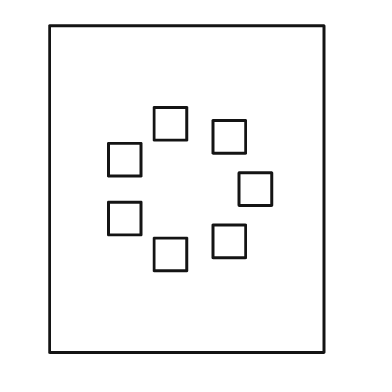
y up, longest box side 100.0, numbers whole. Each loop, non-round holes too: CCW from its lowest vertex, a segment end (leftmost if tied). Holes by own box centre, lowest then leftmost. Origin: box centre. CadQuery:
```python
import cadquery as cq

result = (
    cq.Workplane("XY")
    .moveTo(-42.0, -50.0)
    .lineTo(42.0, -50.0)
    .lineTo(42.0, 50.0)
    .lineTo(-42.0, 50.0)
    .close()
    .moveTo(-10.0, -25.0)
    .lineTo(0.0, -25.0)
    .lineTo(0.0, -15.0)
    .lineTo(-10.0, -15.0)
    .close()
    .moveTo(8.0, -21.0)
    .lineTo(18.0, -21.0)
    .lineTo(18.0, -11.0)
    .lineTo(8.0, -11.0)
    .close()
    .moveTo(-24.0, -14.0)
    .lineTo(-14.0, -14.0)
    .lineTo(-14.0, -4.0)
    .lineTo(-24.0, -4.0)
    .close()
    .moveTo(16.0, -5.0)
    .lineTo(26.0, -5.0)
    .lineTo(26.0, 5.0)
    .lineTo(16.0, 5.0)
    .close()
    .moveTo(-24.0, 4.0)
    .lineTo(-14.0, 4.0)
    .lineTo(-14.0, 14.0)
    .lineTo(-24.0, 14.0)
    .close()
    .moveTo(8.0, 11.0)
    .lineTo(18.0, 11.0)
    .lineTo(18.0, 21.0)
    .lineTo(8.0, 21.0)
    .close()
    .moveTo(-10.0, 15.0)
    .lineTo(0.0, 15.0)
    .lineTo(0.0, 25.0)
    .lineTo(-10.0, 25.0)
    .close()
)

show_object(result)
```